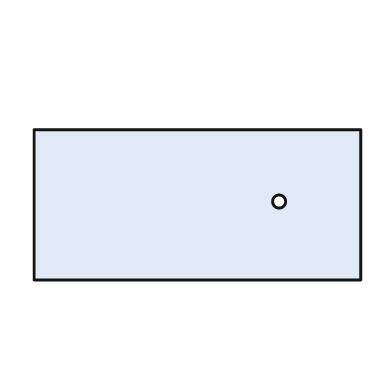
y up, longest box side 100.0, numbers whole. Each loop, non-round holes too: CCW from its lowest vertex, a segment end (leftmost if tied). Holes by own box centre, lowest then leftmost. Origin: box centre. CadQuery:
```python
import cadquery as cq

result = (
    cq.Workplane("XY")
    .moveTo(-50.0, -23.0)
    .lineTo(50.0, -23.0)
    .lineTo(50.0, 23.0)
    .lineTo(-50.0, 23.0)
    .close()
    .moveTo(25.0, 1.0)
    .circle(2.0)
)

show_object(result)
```